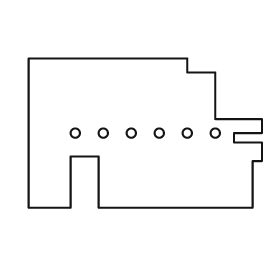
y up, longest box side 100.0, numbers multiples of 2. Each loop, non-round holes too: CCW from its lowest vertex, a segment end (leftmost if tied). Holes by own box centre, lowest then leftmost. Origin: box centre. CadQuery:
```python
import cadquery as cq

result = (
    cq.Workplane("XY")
    .moveTo(-50.0, -32.0)
    .lineTo(-32.0, -32.0)
    .lineTo(-32.0, -10.0)
    .lineTo(-20.0, -10.0)
    .lineTo(-20.0, -32.0)
    .lineTo(46.0, -32.0)
    .lineTo(46.0, -12.0)
    .lineTo(50.0, -12.0)
    .lineTo(50.0, -4.0)
    .lineTo(38.0, -4.0)
    .lineTo(38.0, 0.0)
    .lineTo(50.0, 0.0)
    .lineTo(50.0, 6.0)
    .lineTo(30.0, 6.0)
    .lineTo(30.0, 26.0)
    .lineTo(18.0, 26.0)
    .lineTo(18.0, 32.0)
    .lineTo(-50.0, 32.0)
    .close()
    .moveTo(-30.0, 0.0)
    .circle(2.0)
    .moveTo(-18.0, 0.0)
    .circle(2.0)
    .moveTo(-6.0, 0.0)
    .circle(2.0)
    .moveTo(6.0, 0.0)
    .circle(2.0)
    .moveTo(18.0, 0.0)
    .circle(2.0)
    .moveTo(30.0, 0.0)
    .circle(2.0)
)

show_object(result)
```